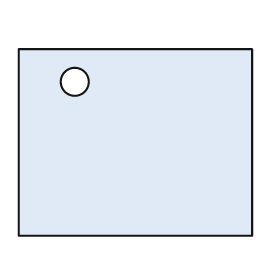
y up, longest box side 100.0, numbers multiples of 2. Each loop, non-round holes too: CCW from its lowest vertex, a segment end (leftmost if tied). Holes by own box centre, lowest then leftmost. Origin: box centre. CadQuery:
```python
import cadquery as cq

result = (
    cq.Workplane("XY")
    .moveTo(-50.0, -40.0)
    .lineTo(50.0, -40.0)
    .lineTo(50.0, 40.0)
    .lineTo(-50.0, 40.0)
    .close()
    .moveTo(-26.0, 26.0)
    .circle(6.0)
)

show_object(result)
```